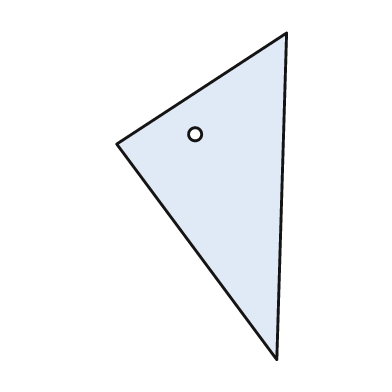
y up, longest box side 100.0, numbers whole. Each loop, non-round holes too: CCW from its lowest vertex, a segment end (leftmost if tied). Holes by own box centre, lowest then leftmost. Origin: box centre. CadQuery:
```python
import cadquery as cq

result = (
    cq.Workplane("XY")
    .moveTo(23.0, -50.0)
    .lineTo(26.0, 50.0)
    .lineTo(-26.0, 16.0)
    .close()
    .moveTo(-2.0, 19.0)
    .circle(2.0)
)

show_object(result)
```